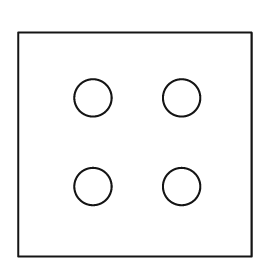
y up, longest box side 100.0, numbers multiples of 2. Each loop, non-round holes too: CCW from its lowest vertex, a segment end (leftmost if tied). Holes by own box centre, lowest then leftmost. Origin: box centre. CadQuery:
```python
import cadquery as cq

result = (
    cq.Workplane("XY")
    .moveTo(-50.0, -48.0)
    .lineTo(50.0, -48.0)
    .lineTo(50.0, 48.0)
    .lineTo(-50.0, 48.0)
    .close()
    .moveTo(-18.0, -18.0)
    .circle(8.0)
    .moveTo(20.0, -18.0)
    .circle(8.0)
    .moveTo(-18.0, 20.0)
    .circle(8.0)
    .moveTo(20.0, 20.0)
    .circle(8.0)
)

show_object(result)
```